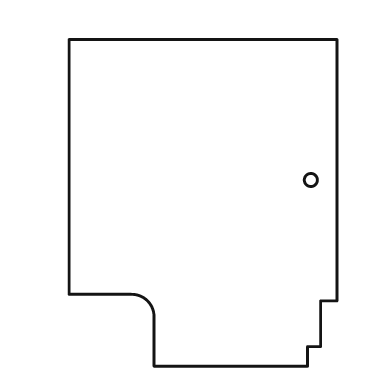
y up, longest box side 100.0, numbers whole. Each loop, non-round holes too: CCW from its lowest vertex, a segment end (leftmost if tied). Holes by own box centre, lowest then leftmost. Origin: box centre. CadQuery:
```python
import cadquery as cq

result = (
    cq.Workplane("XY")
    .moveTo(-15.0, -50.0)
    .lineTo(32.0, -50.0)
    .lineTo(32.0, -44.0)
    .lineTo(36.0, -44.0)
    .lineTo(36.0, -30.0)
    .lineTo(41.0, -30.0)
    .lineTo(41.0, 50.0)
    .lineTo(-41.0, 50.0)
    .lineTo(-41.0, -28.0)
    .lineTo(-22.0, -28.0)
    .threePointArc((-17.0, -30.0), (-15.0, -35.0))
    .close()
    .moveTo(33.0, 7.0)
    .circle(2.0)
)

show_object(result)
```